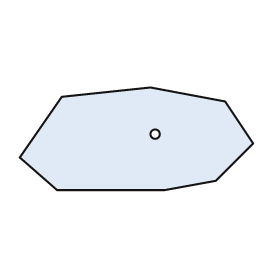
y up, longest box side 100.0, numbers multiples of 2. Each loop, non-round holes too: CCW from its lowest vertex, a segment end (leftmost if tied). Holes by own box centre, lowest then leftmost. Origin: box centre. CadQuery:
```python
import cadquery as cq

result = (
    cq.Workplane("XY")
    .moveTo(-34.0, -22.0)
    .lineTo(12.0, -22.0)
    .lineTo(34.0, -18.0)
    .lineTo(50.0, -2.0)
    .lineTo(38.0, 16.0)
    .lineTo(6.0, 22.0)
    .lineTo(-32.0, 18.0)
    .lineTo(-50.0, -8.0)
    .close()
    .moveTo(8.0, 2.0)
    .circle(2.0)
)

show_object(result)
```